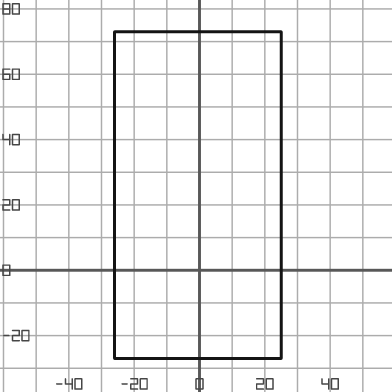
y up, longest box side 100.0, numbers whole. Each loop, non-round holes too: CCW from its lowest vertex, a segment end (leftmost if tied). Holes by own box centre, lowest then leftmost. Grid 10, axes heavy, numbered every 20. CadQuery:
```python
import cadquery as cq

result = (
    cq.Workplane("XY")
    .moveTo(-26.0, -27.0)
    .lineTo(25.0, -27.0)
    .lineTo(25.0, 73.0)
    .lineTo(-26.0, 73.0)
    .close()
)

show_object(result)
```